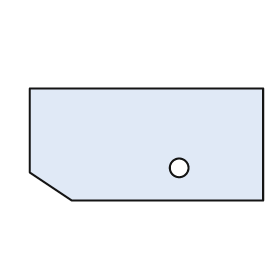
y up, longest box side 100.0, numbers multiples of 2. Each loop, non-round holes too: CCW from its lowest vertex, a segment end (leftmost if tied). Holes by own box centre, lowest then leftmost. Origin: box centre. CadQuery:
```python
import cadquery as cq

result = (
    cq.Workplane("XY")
    .moveTo(-32.0, -24.0)
    .lineTo(50.0, -24.0)
    .lineTo(50.0, 24.0)
    .lineTo(-50.0, 24.0)
    .lineTo(-50.0, -12.0)
    .close()
    .moveTo(14.0, -10.0)
    .circle(4.0)
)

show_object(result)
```